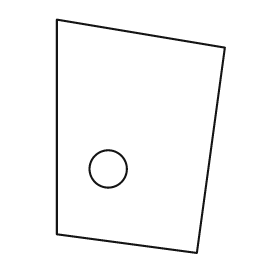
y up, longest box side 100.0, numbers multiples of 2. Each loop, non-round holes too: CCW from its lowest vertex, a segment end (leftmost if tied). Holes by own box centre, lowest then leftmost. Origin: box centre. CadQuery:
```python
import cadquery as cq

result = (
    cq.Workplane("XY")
    .moveTo(24.0, -50.0)
    .lineTo(36.0, 38.0)
    .lineTo(-36.0, 50.0)
    .lineTo(-36.0, -42.0)
    .close()
    .moveTo(-14.0, -14.0)
    .circle(8.0)
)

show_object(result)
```